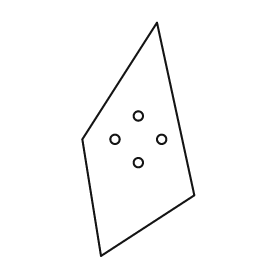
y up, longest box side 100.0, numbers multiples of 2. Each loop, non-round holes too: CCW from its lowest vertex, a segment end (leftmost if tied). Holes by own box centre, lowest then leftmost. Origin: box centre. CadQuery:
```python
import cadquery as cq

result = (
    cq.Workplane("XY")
    .moveTo(-16.0, -50.0)
    .lineTo(24.0, -24.0)
    .lineTo(8.0, 50.0)
    .lineTo(-24.0, 0.0)
    .close()
    .moveTo(0.0, -10.0)
    .circle(2.0)
    .moveTo(-10.0, 0.0)
    .circle(2.0)
    .moveTo(10.0, 0.0)
    .circle(2.0)
    .moveTo(0.0, 10.0)
    .circle(2.0)
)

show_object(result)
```